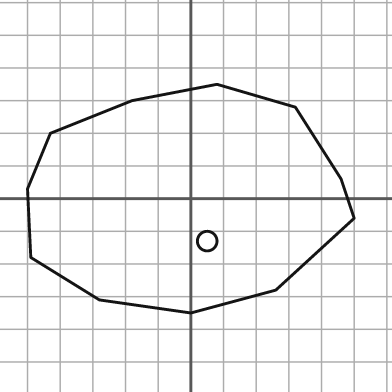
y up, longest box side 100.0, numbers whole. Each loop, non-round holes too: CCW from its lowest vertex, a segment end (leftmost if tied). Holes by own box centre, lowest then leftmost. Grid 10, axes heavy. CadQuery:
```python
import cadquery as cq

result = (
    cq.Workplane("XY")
    .moveTo(0.0, -35.0)
    .lineTo(26.0, -28.0)
    .lineTo(50.0, -6.0)
    .lineTo(46.0, 6.0)
    .lineTo(32.0, 28.0)
    .lineTo(8.0, 35.0)
    .lineTo(-18.0, 30.0)
    .lineTo(-43.0, 20.0)
    .lineTo(-50.0, 3.0)
    .lineTo(-49.0, -18.0)
    .lineTo(-28.0, -31.0)
    .close()
    .moveTo(5.0, -13.0)
    .circle(3.0)
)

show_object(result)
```